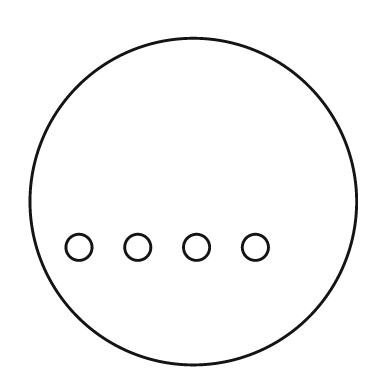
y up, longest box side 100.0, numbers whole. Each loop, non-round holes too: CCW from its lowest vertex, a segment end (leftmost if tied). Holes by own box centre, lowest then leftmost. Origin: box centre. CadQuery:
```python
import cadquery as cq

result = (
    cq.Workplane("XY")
    .moveTo(0.0, 0.0)
    .circle(50.0)
    .moveTo(-35.0, -14.0)
    .circle(4.0)
    .moveTo(-17.0, -14.0)
    .circle(4.0)
    .moveTo(1.0, -14.0)
    .circle(4.0)
    .moveTo(19.0, -14.0)
    .circle(4.0)
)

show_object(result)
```